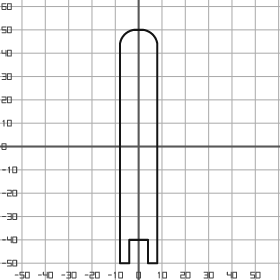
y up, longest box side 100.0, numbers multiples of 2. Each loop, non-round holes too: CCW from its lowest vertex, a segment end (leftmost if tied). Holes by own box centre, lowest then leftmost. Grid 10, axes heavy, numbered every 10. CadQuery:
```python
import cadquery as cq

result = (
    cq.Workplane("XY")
    .moveTo(-8.0, -50.0)
    .lineTo(-4.0, -50.0)
    .lineTo(-4.0, -40.0)
    .lineTo(4.0, -40.0)
    .lineTo(4.0, -50.0)
    .lineTo(8.0, -50.0)
    .lineTo(8.0, 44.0)
    .threePointArc((6.0, 48.0), (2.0, 50.0))
    .lineTo(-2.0, 50.0)
    .threePointArc((-6.0, 48.0), (-8.0, 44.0))
    .close()
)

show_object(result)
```